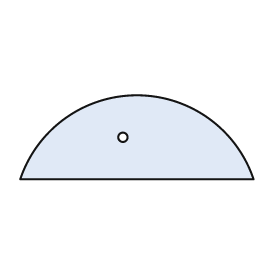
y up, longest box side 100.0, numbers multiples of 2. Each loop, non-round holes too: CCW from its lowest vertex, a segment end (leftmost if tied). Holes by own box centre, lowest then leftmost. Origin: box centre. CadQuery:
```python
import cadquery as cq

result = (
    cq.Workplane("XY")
    .moveTo(-50.0, -18.0)
    .lineTo(50.0, -18.0)
    .threePointArc((0.0, 18.0), (-50.0, -18.0))
    .close()
    .moveTo(-6.0, 0.0)
    .circle(2.0)
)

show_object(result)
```